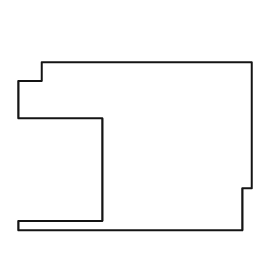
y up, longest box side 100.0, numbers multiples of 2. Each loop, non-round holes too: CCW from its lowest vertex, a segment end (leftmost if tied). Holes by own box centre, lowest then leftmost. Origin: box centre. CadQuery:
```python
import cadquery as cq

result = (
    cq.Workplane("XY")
    .moveTo(-50.0, -36.0)
    .lineTo(46.0, -36.0)
    .lineTo(46.0, -18.0)
    .lineTo(50.0, -18.0)
    .lineTo(50.0, 36.0)
    .lineTo(-40.0, 36.0)
    .lineTo(-40.0, 28.0)
    .lineTo(-50.0, 28.0)
    .lineTo(-50.0, 12.0)
    .lineTo(-14.0, 12.0)
    .lineTo(-14.0, -32.0)
    .lineTo(-50.0, -32.0)
    .close()
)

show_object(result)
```